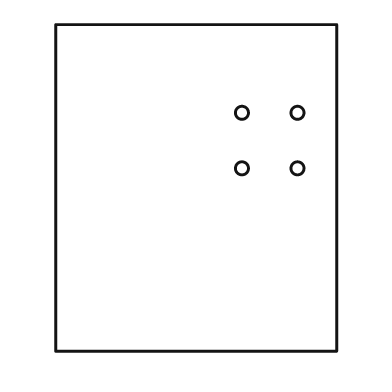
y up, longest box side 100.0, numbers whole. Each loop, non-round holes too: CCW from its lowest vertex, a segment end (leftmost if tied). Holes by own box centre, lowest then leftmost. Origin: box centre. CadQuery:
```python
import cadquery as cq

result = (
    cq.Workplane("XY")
    .moveTo(-43.0, -50.0)
    .lineTo(43.0, -50.0)
    .lineTo(43.0, 50.0)
    .lineTo(-43.0, 50.0)
    .close()
    .moveTo(14.0, 6.0)
    .circle(2.0)
    .moveTo(31.0, 6.0)
    .circle(2.0)
    .moveTo(14.0, 23.0)
    .circle(2.0)
    .moveTo(31.0, 23.0)
    .circle(2.0)
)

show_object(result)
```